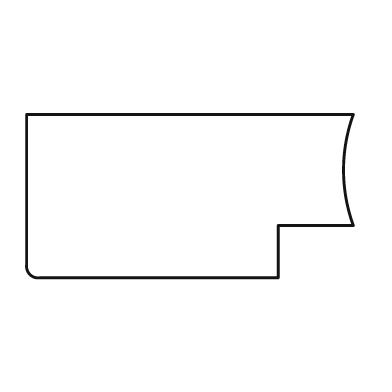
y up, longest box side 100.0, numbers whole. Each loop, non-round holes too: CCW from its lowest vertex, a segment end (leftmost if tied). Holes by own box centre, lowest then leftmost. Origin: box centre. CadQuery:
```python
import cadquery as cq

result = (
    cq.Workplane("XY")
    .moveTo(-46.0, -25.0)
    .lineTo(27.0, -25.0)
    .lineTo(27.0, -9.0)
    .lineTo(50.0, -9.0)
    .threePointArc((47.0, 8.0), (50.0, 25.0))
    .lineTo(-50.0, 25.0)
    .lineTo(-50.0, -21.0)
    .threePointArc((-49.0, -24.0), (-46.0, -25.0))
    .close()
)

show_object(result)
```